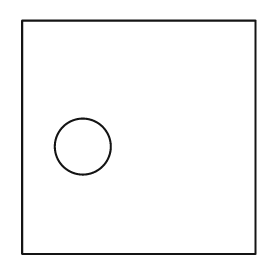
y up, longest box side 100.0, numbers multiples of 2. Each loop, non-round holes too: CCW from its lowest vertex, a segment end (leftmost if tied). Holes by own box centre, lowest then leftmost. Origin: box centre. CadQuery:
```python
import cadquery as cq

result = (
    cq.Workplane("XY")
    .moveTo(-50.0, -50.0)
    .lineTo(50.0, -50.0)
    .lineTo(50.0, 50.0)
    .lineTo(-50.0, 50.0)
    .close()
    .moveTo(-24.0, -4.0)
    .circle(12.0)
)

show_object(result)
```